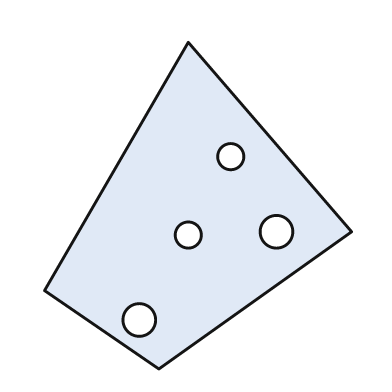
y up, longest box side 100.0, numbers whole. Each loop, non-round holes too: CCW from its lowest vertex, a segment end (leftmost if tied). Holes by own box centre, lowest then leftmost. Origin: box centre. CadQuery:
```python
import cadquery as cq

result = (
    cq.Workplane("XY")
    .moveTo(-12.0, -50.0)
    .lineTo(47.0, -8.0)
    .lineTo(-3.0, 50.0)
    .lineTo(-47.0, -26.0)
    .close()
    .moveTo(-18.0, -35.0)
    .circle(5.0)
    .moveTo(-3.0, -9.0)
    .circle(4.0)
    .moveTo(24.0, -8.0)
    .circle(5.0)
    .moveTo(10.0, 15.0)
    .circle(4.0)
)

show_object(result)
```